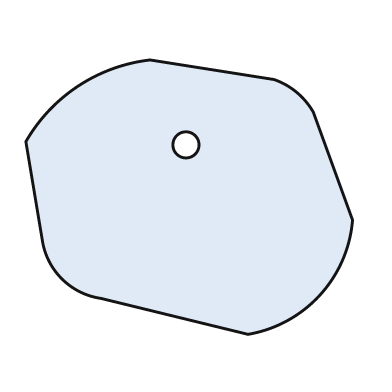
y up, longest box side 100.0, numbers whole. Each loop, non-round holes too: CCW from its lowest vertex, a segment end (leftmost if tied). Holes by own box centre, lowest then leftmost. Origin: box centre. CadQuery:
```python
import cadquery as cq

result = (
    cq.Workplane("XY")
    .moveTo(18.0, -42.0)
    .threePointArc((40.0, -30.0), (50.0, -7.0))
    .lineTo(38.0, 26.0)
    .threePointArc((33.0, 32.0), (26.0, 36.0))
    .lineTo(-12.0, 42.0)
    .threePointArc((-34.0, 34.0), (-50.0, 17.0))
    .lineTo(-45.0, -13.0)
    .threePointArc((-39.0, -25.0), (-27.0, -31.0))
    .close()
    .moveTo(-1.0, 16.0)
    .circle(4.0)
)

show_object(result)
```